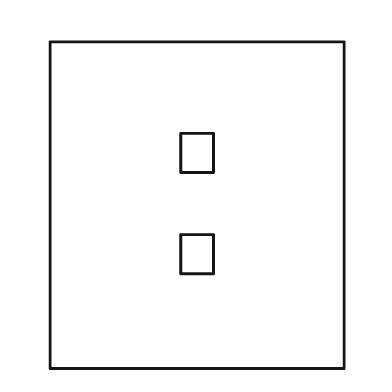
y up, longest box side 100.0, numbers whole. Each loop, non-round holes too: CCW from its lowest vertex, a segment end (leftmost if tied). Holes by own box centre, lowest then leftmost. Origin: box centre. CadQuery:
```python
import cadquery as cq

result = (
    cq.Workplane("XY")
    .moveTo(-45.0, -50.0)
    .lineTo(45.0, -50.0)
    .lineTo(45.0, 50.0)
    .lineTo(-45.0, 50.0)
    .close()
    .moveTo(-5.0, -21.0)
    .lineTo(5.0, -21.0)
    .lineTo(5.0, -9.0)
    .lineTo(-5.0, -9.0)
    .close()
    .moveTo(-5.0, 10.0)
    .lineTo(5.0, 10.0)
    .lineTo(5.0, 22.0)
    .lineTo(-5.0, 22.0)
    .close()
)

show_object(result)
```